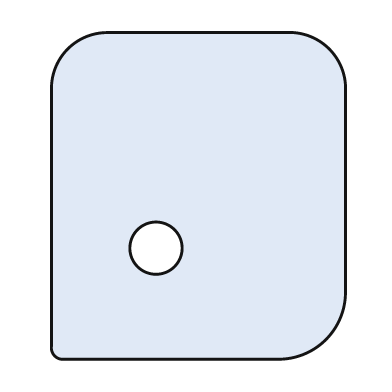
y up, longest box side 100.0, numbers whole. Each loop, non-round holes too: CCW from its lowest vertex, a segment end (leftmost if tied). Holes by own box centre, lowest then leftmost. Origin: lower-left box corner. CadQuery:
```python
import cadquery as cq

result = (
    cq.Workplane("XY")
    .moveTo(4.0, 0.0)
    .lineTo(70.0, 0.0)
    .threePointArc((84.0, 6.0), (90.0, 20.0))
    .lineTo(90.0, 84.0)
    .threePointArc((85.0, 95.0), (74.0, 100.0))
    .lineTo(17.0, 100.0)
    .threePointArc((5.0, 95.0), (0.0, 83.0))
    .lineTo(0.0, 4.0)
    .threePointArc((1.0, 1.0), (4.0, 0.0))
    .close()
    .moveTo(32.0, 34.0)
    .circle(8.0)
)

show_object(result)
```